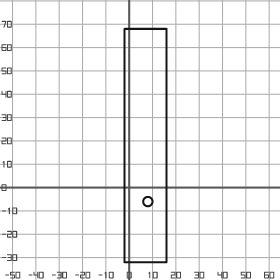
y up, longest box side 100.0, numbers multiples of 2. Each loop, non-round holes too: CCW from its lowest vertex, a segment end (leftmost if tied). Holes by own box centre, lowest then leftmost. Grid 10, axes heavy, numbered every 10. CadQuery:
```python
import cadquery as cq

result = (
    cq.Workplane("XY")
    .moveTo(-2.0, -32.0)
    .lineTo(16.0, -32.0)
    .lineTo(16.0, 68.0)
    .lineTo(-2.0, 68.0)
    .close()
    .moveTo(8.0, -6.0)
    .circle(2.0)
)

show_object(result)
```